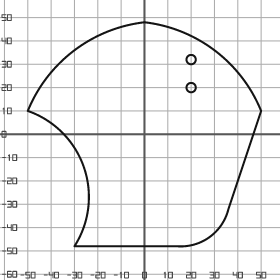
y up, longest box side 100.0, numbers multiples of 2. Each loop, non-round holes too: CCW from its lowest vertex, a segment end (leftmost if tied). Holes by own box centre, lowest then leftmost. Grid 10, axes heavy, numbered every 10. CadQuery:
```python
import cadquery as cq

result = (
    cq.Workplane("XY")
    .moveTo(-30.0, -48.0)
    .lineTo(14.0, -48.0)
    .threePointArc((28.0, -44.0), (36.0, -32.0))
    .lineTo(50.0, 10.0)
    .threePointArc((30.0, 36.0), (0.0, 48.0))
    .threePointArc((-30.0, 36.0), (-50.0, 10.0))
    .threePointArc((-26.0, -14.0), (-30.0, -48.0))
    .close()
    .moveTo(20.0, 20.0)
    .circle(2.0)
    .moveTo(20.0, 32.0)
    .circle(2.0)
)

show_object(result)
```